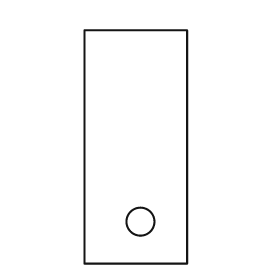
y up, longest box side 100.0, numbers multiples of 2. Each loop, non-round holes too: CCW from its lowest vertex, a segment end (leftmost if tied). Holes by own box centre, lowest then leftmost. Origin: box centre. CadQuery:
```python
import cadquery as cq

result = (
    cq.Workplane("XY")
    .moveTo(-22.0, -50.0)
    .lineTo(22.0, -50.0)
    .lineTo(22.0, 50.0)
    .lineTo(-22.0, 50.0)
    .close()
    .moveTo(2.0, -32.0)
    .circle(6.0)
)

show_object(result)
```